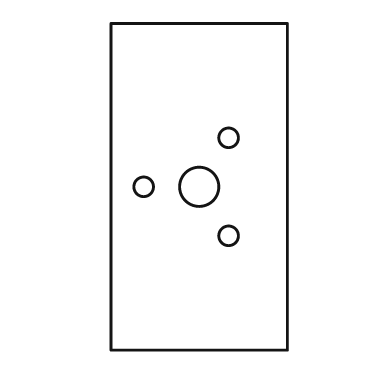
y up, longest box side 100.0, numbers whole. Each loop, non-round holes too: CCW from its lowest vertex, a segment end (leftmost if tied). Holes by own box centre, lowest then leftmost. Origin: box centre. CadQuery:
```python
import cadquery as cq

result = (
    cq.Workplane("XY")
    .moveTo(-27.0, -50.0)
    .lineTo(27.0, -50.0)
    .lineTo(27.0, 50.0)
    .lineTo(-27.0, 50.0)
    .close()
    .moveTo(9.0, -15.0)
    .circle(3.0)
    .moveTo(-17.0, 0.0)
    .circle(3.0)
    .moveTo(0.0, 0.0)
    .circle(6.0)
    .moveTo(9.0, 15.0)
    .circle(3.0)
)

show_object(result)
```